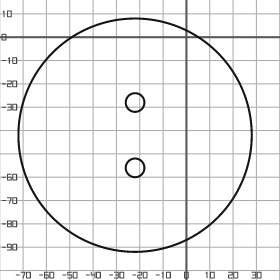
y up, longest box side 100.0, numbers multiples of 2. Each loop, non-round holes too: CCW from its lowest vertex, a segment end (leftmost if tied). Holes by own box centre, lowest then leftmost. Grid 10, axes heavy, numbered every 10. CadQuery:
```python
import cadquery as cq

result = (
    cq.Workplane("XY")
    .moveTo(-22.0, -42.0)
    .circle(50.0)
    .moveTo(-22.0, -56.0)
    .circle(4.0)
    .moveTo(-22.0, -28.0)
    .circle(4.0)
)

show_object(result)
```